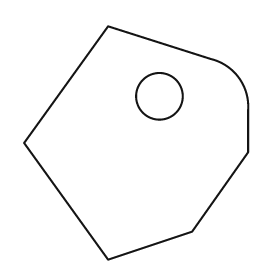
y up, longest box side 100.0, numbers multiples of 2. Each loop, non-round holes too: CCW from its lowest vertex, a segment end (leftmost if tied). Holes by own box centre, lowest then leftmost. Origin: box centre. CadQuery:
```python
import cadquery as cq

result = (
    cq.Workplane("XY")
    .moveTo(-12.0, -50.0)
    .lineTo(24.0, -38.0)
    .lineTo(48.0, -4.0)
    .lineTo(48.0, 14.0)
    .threePointArc((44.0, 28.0), (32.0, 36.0))
    .lineTo(-12.0, 50.0)
    .lineTo(-48.0, 0.0)
    .close()
    .moveTo(10.0, 20.0)
    .circle(10.0)
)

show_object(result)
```